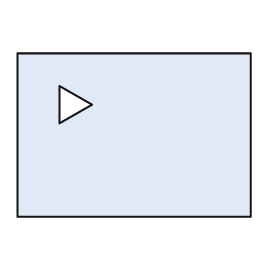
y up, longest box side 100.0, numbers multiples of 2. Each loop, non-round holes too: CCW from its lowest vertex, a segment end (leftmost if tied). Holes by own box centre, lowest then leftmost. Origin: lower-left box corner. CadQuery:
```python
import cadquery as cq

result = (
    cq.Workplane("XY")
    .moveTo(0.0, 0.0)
    .lineTo(100.0, 0.0)
    .lineTo(100.0, 70.0)
    .lineTo(0.0, 70.0)
    .close()
    .moveTo(18.0, 40.0)
    .lineTo(32.0, 48.0)
    .lineTo(18.0, 56.0)
    .close()
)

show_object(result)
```